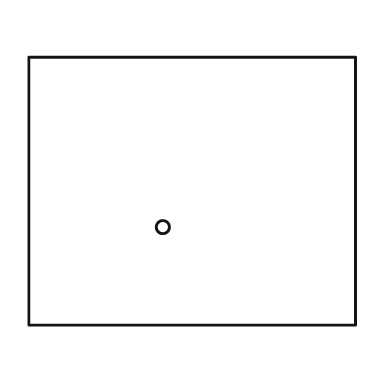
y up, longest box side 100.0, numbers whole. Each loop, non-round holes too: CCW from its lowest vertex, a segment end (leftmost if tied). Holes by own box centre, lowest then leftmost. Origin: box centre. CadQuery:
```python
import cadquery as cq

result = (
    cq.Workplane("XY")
    .moveTo(-50.0, -41.0)
    .lineTo(50.0, -41.0)
    .lineTo(50.0, 41.0)
    .lineTo(-50.0, 41.0)
    .close()
    .moveTo(-9.0, -11.0)
    .circle(2.0)
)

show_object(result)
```